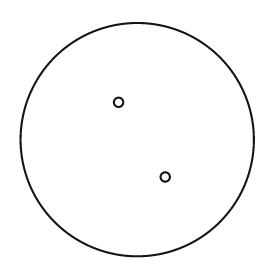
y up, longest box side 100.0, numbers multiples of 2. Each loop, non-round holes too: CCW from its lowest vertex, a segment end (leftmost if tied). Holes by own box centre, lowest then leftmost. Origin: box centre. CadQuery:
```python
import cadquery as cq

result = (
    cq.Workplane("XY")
    .moveTo(0.0, 0.0)
    .circle(50.0)
    .moveTo(12.0, -16.0)
    .circle(2.0)
    .moveTo(-8.0, 16.0)
    .circle(2.0)
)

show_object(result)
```